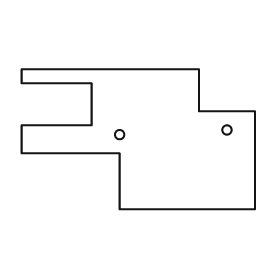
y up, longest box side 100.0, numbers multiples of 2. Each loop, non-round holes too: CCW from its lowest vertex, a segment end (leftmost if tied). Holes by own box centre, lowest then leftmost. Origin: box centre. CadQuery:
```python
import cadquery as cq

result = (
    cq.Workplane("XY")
    .moveTo(-8.0, -30.0)
    .lineTo(50.0, -30.0)
    .lineTo(50.0, 12.0)
    .lineTo(26.0, 12.0)
    .lineTo(26.0, 30.0)
    .lineTo(-50.0, 30.0)
    .lineTo(-50.0, 24.0)
    .lineTo(-20.0, 24.0)
    .lineTo(-20.0, 6.0)
    .lineTo(-50.0, 6.0)
    .lineTo(-50.0, -6.0)
    .lineTo(-8.0, -6.0)
    .close()
    .moveTo(-8.0, 2.0)
    .circle(2.0)
    .moveTo(38.0, 4.0)
    .circle(2.0)
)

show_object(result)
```